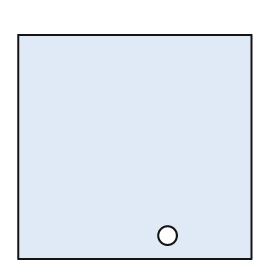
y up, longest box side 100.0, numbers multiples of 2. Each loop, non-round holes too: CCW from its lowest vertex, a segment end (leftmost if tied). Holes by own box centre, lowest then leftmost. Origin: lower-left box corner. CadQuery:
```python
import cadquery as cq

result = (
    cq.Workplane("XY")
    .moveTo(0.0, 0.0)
    .lineTo(100.0, 0.0)
    .lineTo(100.0, 96.0)
    .lineTo(0.0, 96.0)
    .close()
    .moveTo(64.0, 10.0)
    .circle(4.0)
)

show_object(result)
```